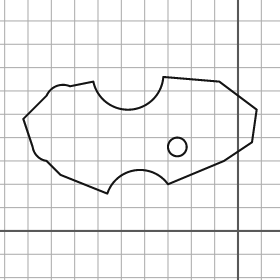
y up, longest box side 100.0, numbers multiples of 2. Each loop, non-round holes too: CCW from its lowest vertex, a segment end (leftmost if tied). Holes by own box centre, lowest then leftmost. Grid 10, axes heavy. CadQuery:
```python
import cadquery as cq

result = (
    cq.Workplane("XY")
    .moveTo(-56.0, 16.0)
    .threePointArc((-44.0, 26.0), (-30.0, 20.0))
    .lineTo(-6.0, 30.0)
    .lineTo(6.0, 38.0)
    .lineTo(8.0, 52.0)
    .lineTo(-8.0, 64.0)
    .lineTo(-32.0, 66.0)
    .threePointArc((-46.0, 52.0), (-62.0, 64.0))
    .lineTo(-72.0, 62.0)
    .threePointArc((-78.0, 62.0), (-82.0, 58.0))
    .lineTo(-92.0, 48.0)
    .lineTo(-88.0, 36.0)
    .threePointArc((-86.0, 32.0), (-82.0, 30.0))
    .lineTo(-76.0, 24.0)
    .close()
    .moveTo(-26.0, 36.0)
    .circle(4.0)
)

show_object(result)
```